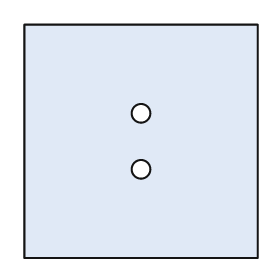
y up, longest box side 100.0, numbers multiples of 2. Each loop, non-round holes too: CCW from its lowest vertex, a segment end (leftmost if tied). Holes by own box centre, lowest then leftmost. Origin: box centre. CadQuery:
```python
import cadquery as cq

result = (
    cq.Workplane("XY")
    .moveTo(-50.0, -50.0)
    .lineTo(50.0, -50.0)
    .lineTo(50.0, 50.0)
    .lineTo(-50.0, 50.0)
    .close()
    .moveTo(0.0, -12.0)
    .circle(4.0)
    .moveTo(0.0, 12.0)
    .circle(4.0)
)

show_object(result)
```